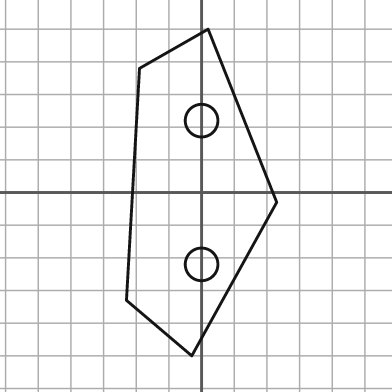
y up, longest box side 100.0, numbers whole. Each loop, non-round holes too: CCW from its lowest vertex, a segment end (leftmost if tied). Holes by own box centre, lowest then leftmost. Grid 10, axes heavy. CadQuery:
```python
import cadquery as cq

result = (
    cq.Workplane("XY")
    .moveTo(-3.0, -50.0)
    .lineTo(23.0, -3.0)
    .lineTo(2.0, 50.0)
    .lineTo(-19.0, 38.0)
    .lineTo(-23.0, -33.0)
    .close()
    .moveTo(0.0, -22.0)
    .circle(5.0)
    .moveTo(0.0, 22.0)
    .circle(5.0)
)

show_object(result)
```